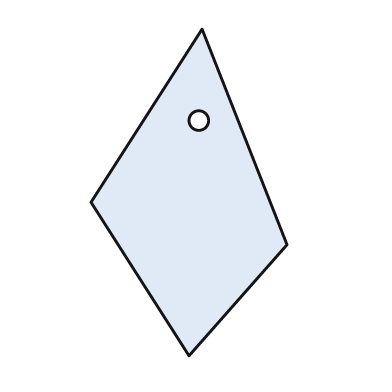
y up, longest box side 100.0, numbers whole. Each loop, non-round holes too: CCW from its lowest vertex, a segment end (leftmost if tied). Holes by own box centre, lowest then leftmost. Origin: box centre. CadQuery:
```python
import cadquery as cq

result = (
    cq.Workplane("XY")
    .moveTo(0.0, -50.0)
    .lineTo(30.0, -16.0)
    .lineTo(4.0, 50.0)
    .lineTo(-30.0, -3.0)
    .close()
    .moveTo(3.0, 22.0)
    .circle(3.0)
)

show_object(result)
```